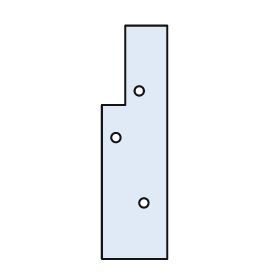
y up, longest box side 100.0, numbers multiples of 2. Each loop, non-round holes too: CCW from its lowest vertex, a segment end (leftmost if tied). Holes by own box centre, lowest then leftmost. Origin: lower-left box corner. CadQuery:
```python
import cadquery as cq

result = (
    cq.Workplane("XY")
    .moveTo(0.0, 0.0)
    .lineTo(28.0, 0.0)
    .lineTo(28.0, 100.0)
    .lineTo(10.0, 100.0)
    .lineTo(10.0, 66.0)
    .lineTo(0.0, 66.0)
    .close()
    .moveTo(18.0, 24.0)
    .circle(2.0)
    .moveTo(6.0, 52.0)
    .circle(2.0)
    .moveTo(16.0, 72.0)
    .circle(2.0)
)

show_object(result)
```